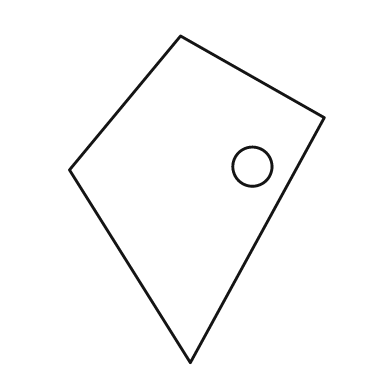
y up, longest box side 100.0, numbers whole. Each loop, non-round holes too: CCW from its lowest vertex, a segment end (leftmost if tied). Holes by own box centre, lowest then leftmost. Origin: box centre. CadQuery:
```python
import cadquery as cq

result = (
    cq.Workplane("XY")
    .moveTo(-2.0, -50.0)
    .lineTo(39.0, 25.0)
    .lineTo(-5.0, 50.0)
    .lineTo(-39.0, 9.0)
    .close()
    .moveTo(17.0, 10.0)
    .circle(6.0)
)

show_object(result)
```